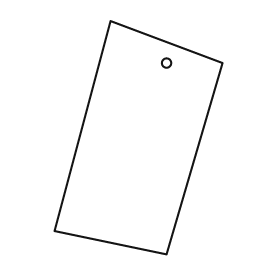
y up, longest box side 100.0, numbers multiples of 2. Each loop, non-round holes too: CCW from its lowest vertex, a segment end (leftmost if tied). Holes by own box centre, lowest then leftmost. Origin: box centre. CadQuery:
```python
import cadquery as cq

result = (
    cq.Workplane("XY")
    .moveTo(12.0, -50.0)
    .lineTo(36.0, 32.0)
    .lineTo(-12.0, 50.0)
    .lineTo(-36.0, -40.0)
    .close()
    .moveTo(12.0, 32.0)
    .circle(2.0)
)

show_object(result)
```